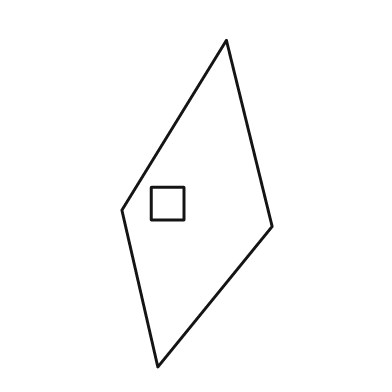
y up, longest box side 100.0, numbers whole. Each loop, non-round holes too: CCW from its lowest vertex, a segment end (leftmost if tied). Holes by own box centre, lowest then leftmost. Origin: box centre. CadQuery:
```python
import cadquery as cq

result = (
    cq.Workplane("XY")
    .moveTo(-12.0, -50.0)
    .lineTo(23.0, -7.0)
    .lineTo(9.0, 50.0)
    .lineTo(-23.0, -2.0)
    .close()
    .moveTo(-14.0, -5.0)
    .lineTo(-4.0, -5.0)
    .lineTo(-4.0, 5.0)
    .lineTo(-14.0, 5.0)
    .close()
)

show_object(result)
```